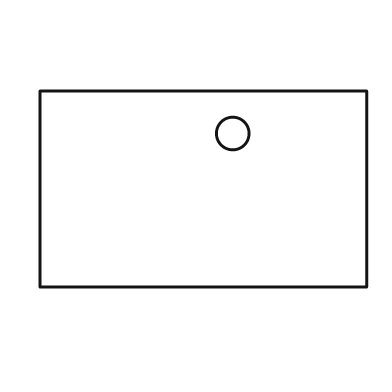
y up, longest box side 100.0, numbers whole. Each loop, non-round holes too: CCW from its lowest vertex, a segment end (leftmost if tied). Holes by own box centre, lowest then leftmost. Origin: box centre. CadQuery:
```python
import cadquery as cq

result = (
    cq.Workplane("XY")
    .moveTo(-50.0, -30.0)
    .lineTo(50.0, -30.0)
    .lineTo(50.0, 30.0)
    .lineTo(-50.0, 30.0)
    .close()
    .moveTo(9.0, 17.0)
    .circle(5.0)
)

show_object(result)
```